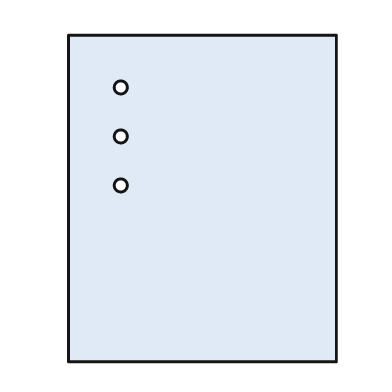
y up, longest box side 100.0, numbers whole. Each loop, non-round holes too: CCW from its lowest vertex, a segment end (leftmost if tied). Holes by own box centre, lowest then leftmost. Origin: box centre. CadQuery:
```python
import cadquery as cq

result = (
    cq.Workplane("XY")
    .moveTo(-41.0, -50.0)
    .lineTo(41.0, -50.0)
    .lineTo(41.0, 50.0)
    .lineTo(-41.0, 50.0)
    .close()
    .moveTo(-25.0, 4.0)
    .circle(2.0)
    .moveTo(-25.0, 19.0)
    .circle(2.0)
    .moveTo(-25.0, 34.0)
    .circle(2.0)
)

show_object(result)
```